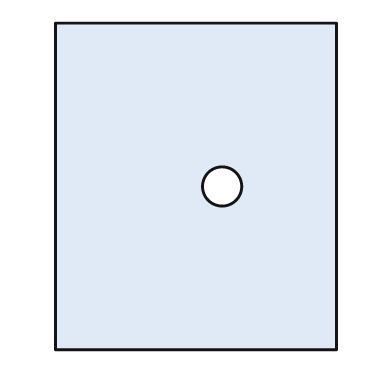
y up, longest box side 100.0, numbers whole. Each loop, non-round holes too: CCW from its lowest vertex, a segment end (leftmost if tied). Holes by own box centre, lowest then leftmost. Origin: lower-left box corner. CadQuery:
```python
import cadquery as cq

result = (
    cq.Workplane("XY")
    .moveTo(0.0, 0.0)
    .lineTo(86.0, 0.0)
    .lineTo(86.0, 100.0)
    .lineTo(0.0, 100.0)
    .close()
    .moveTo(51.0, 50.0)
    .circle(6.0)
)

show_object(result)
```